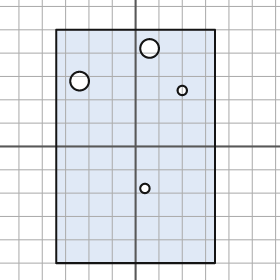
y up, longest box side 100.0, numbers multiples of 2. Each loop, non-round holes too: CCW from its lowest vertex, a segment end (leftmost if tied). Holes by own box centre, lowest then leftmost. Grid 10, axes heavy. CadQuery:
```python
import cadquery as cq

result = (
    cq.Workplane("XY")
    .moveTo(-34.0, -50.0)
    .lineTo(34.0, -50.0)
    .lineTo(34.0, 50.0)
    .lineTo(-34.0, 50.0)
    .close()
    .moveTo(4.0, -18.0)
    .circle(2.0)
    .moveTo(20.0, 24.0)
    .circle(2.0)
    .moveTo(-24.0, 28.0)
    .circle(4.0)
    .moveTo(6.0, 42.0)
    .circle(4.0)
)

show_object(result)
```